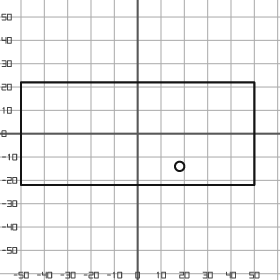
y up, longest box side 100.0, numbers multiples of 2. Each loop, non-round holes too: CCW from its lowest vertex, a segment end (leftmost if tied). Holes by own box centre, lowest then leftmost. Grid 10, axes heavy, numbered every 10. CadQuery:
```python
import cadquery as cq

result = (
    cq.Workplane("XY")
    .moveTo(-50.0, -22.0)
    .lineTo(50.0, -22.0)
    .lineTo(50.0, 22.0)
    .lineTo(-50.0, 22.0)
    .close()
    .moveTo(18.0, -14.0)
    .circle(2.0)
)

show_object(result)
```